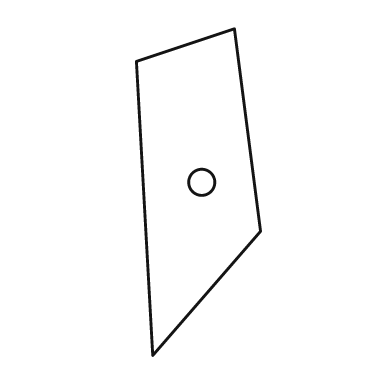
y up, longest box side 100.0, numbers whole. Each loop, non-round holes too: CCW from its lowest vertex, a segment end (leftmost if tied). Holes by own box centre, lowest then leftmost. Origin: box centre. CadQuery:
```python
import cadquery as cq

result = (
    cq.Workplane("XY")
    .moveTo(-14.0, -50.0)
    .lineTo(19.0, -12.0)
    .lineTo(11.0, 50.0)
    .lineTo(-19.0, 40.0)
    .close()
    .moveTo(1.0, 3.0)
    .circle(4.0)
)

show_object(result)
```